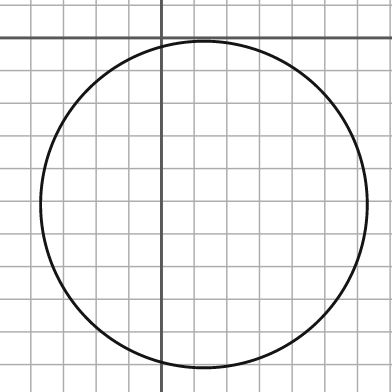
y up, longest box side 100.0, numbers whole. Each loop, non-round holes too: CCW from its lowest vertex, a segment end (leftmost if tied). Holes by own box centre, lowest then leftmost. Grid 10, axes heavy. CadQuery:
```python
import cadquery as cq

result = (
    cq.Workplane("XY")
    .moveTo(13.0, -51.0)
    .circle(50.0)
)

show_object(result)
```